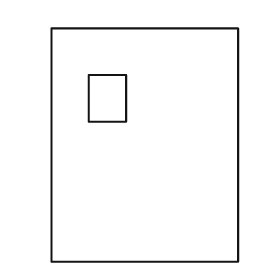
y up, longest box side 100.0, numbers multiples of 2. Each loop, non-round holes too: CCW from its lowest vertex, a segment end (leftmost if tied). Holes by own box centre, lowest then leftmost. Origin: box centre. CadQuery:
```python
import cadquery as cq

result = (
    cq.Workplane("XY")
    .moveTo(-40.0, -50.0)
    .lineTo(40.0, -50.0)
    .lineTo(40.0, 50.0)
    .lineTo(-40.0, 50.0)
    .close()
    .moveTo(-24.0, 10.0)
    .lineTo(-8.0, 10.0)
    .lineTo(-8.0, 30.0)
    .lineTo(-24.0, 30.0)
    .close()
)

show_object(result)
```